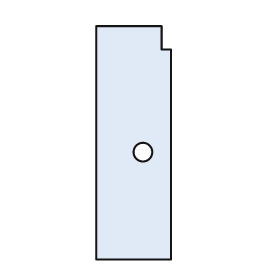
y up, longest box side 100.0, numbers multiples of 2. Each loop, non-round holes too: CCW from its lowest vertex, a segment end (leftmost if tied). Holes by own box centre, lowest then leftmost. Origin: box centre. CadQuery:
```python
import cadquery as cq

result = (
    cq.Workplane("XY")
    .moveTo(-16.0, -50.0)
    .lineTo(16.0, -50.0)
    .lineTo(16.0, 40.0)
    .lineTo(12.0, 40.0)
    .lineTo(12.0, 50.0)
    .lineTo(-16.0, 50.0)
    .close()
    .moveTo(4.0, -4.0)
    .circle(4.0)
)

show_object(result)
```